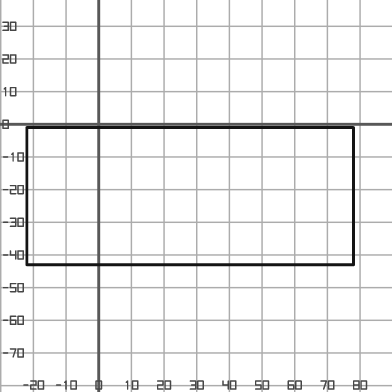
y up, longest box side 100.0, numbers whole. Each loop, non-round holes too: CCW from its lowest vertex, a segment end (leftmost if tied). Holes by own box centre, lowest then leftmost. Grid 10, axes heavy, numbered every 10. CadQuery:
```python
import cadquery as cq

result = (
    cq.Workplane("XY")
    .moveTo(-22.0, -43.0)
    .lineTo(78.0, -43.0)
    .lineTo(78.0, -1.0)
    .lineTo(-22.0, -1.0)
    .close()
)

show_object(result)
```